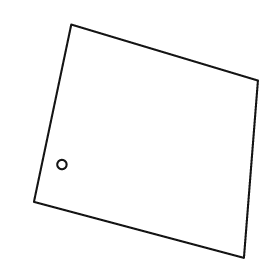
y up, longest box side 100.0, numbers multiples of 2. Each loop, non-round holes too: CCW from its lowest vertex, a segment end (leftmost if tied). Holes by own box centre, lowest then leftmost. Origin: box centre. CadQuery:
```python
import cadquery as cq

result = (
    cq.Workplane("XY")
    .moveTo(42.0, -50.0)
    .lineTo(48.0, 26.0)
    .lineTo(-32.0, 50.0)
    .lineTo(-48.0, -26.0)
    .close()
    .moveTo(-36.0, -10.0)
    .circle(2.0)
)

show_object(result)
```